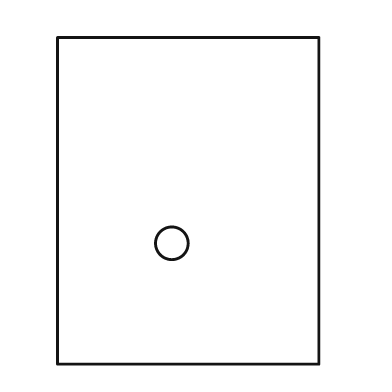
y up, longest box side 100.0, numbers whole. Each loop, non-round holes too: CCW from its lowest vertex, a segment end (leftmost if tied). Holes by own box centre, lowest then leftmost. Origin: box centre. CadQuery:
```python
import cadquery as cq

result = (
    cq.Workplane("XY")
    .moveTo(-40.0, -50.0)
    .lineTo(40.0, -50.0)
    .lineTo(40.0, 50.0)
    .lineTo(-40.0, 50.0)
    .close()
    .moveTo(-5.0, -13.0)
    .circle(5.0)
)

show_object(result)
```